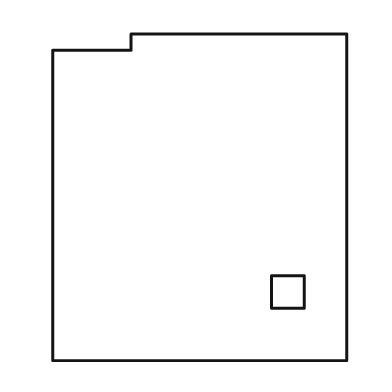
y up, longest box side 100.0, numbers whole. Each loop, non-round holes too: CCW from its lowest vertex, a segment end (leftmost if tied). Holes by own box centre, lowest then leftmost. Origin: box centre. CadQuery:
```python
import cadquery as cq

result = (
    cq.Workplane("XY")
    .moveTo(-45.0, -50.0)
    .lineTo(45.0, -50.0)
    .lineTo(45.0, 50.0)
    .lineTo(-21.0, 50.0)
    .lineTo(-21.0, 45.0)
    .lineTo(-45.0, 45.0)
    .close()
    .moveTo(22.0, -34.0)
    .lineTo(32.0, -34.0)
    .lineTo(32.0, -24.0)
    .lineTo(22.0, -24.0)
    .close()
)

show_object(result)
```